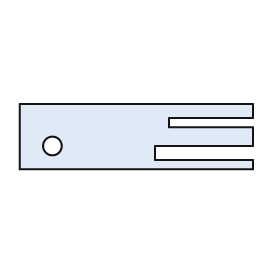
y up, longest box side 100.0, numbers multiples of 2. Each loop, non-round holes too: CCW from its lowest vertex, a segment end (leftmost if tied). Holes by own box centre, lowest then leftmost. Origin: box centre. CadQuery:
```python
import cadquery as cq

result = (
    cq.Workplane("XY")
    .moveTo(-50.0, -14.0)
    .lineTo(50.0, -14.0)
    .lineTo(50.0, -10.0)
    .lineTo(8.0, -10.0)
    .lineTo(8.0, -4.0)
    .lineTo(50.0, -4.0)
    .lineTo(50.0, 4.0)
    .lineTo(14.0, 4.0)
    .lineTo(14.0, 8.0)
    .lineTo(50.0, 8.0)
    .lineTo(50.0, 14.0)
    .lineTo(-50.0, 14.0)
    .close()
    .moveTo(-36.0, -4.0)
    .circle(4.0)
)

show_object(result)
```